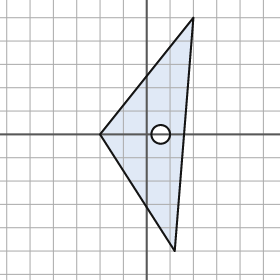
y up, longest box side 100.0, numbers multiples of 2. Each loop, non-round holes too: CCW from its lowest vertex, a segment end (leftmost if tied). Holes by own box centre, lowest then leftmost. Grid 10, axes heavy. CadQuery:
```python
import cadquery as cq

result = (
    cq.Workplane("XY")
    .moveTo(12.0, -50.0)
    .lineTo(20.0, 50.0)
    .lineTo(-20.0, 0.0)
    .close()
    .moveTo(6.0, 0.0)
    .circle(4.0)
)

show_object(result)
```